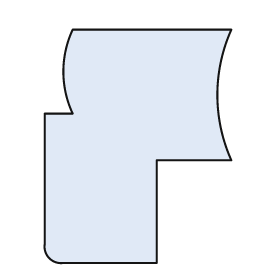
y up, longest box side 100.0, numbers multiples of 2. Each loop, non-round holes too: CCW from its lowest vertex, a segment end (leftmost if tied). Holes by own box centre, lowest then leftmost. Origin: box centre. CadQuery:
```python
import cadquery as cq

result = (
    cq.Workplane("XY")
    .moveTo(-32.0, -50.0)
    .lineTo(8.0, -50.0)
    .lineTo(8.0, -6.0)
    .lineTo(40.0, -6.0)
    .threePointArc((34.0, 22.0), (40.0, 50.0))
    .lineTo(-28.0, 50.0)
    .threePointArc((-32.0, 32.0), (-28.0, 14.0))
    .lineTo(-40.0, 14.0)
    .lineTo(-40.0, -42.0)
    .threePointArc((-38.0, -48.0), (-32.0, -50.0))
    .close()
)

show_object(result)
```